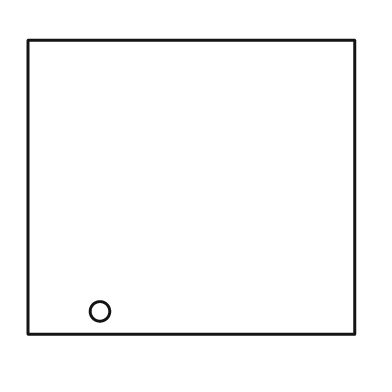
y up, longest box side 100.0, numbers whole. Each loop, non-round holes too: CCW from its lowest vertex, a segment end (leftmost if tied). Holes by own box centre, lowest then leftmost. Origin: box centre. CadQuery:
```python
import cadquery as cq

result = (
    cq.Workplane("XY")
    .moveTo(-50.0, -45.0)
    .lineTo(50.0, -45.0)
    .lineTo(50.0, 45.0)
    .lineTo(-50.0, 45.0)
    .close()
    .moveTo(-28.0, -38.0)
    .circle(3.0)
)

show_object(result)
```